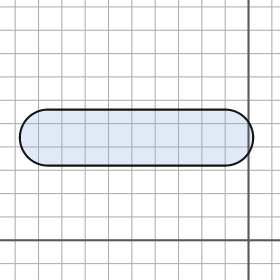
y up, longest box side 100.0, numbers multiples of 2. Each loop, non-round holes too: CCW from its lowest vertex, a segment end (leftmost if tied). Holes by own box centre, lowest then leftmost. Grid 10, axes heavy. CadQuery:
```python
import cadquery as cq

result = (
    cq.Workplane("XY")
    .moveTo(-86.0, 32.0)
    .lineTo(-10.0, 32.0)
    .threePointArc((2.0, 44.0), (-10.0, 56.0))
    .lineTo(-86.0, 56.0)
    .threePointArc((-98.0, 44.0), (-86.0, 32.0))
    .close()
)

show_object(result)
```